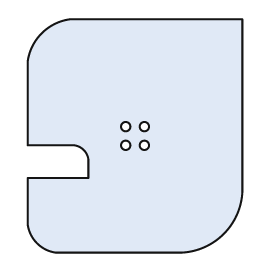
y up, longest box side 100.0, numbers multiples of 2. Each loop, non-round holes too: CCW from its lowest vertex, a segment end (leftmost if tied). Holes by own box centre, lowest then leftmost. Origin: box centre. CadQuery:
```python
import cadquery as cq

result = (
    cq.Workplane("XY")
    .moveTo(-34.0, -50.0)
    .lineTo(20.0, -50.0)
    .threePointArc((38.0, -42.0), (46.0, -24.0))
    .lineTo(46.0, 50.0)
    .lineTo(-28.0, 50.0)
    .threePointArc((-40.0, 44.0), (-46.0, 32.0))
    .lineTo(-46.0, -4.0)
    .lineTo(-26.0, -4.0)
    .threePointArc((-22.0, -6.0), (-20.0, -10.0))
    .lineTo(-20.0, -18.0)
    .lineTo(-46.0, -18.0)
    .lineTo(-46.0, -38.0)
    .threePointArc((-42.0, -46.0), (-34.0, -50.0))
    .close()
    .moveTo(-4.0, -4.0)
    .circle(2.0)
    .moveTo(4.0, -4.0)
    .circle(2.0)
    .moveTo(-4.0, 4.0)
    .circle(2.0)
    .moveTo(4.0, 4.0)
    .circle(2.0)
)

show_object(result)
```